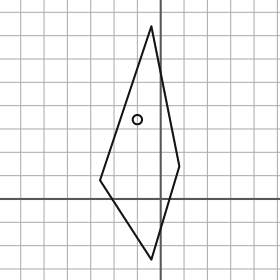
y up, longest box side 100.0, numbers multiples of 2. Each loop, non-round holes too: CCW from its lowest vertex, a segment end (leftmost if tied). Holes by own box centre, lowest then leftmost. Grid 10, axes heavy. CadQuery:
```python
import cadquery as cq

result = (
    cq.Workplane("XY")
    .moveTo(-4.0, -26.0)
    .lineTo(8.0, 14.0)
    .lineTo(-4.0, 74.0)
    .lineTo(-26.0, 8.0)
    .close()
    .moveTo(-10.0, 34.0)
    .circle(2.0)
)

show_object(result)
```